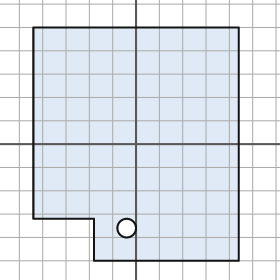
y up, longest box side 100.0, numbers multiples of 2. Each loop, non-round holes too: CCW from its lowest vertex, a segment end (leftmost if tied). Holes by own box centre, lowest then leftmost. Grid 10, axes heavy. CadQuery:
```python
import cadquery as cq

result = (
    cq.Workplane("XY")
    .moveTo(-18.0, -50.0)
    .lineTo(44.0, -50.0)
    .lineTo(44.0, 50.0)
    .lineTo(-44.0, 50.0)
    .lineTo(-44.0, -32.0)
    .lineTo(-18.0, -32.0)
    .close()
    .moveTo(-4.0, -36.0)
    .circle(4.0)
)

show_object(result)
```